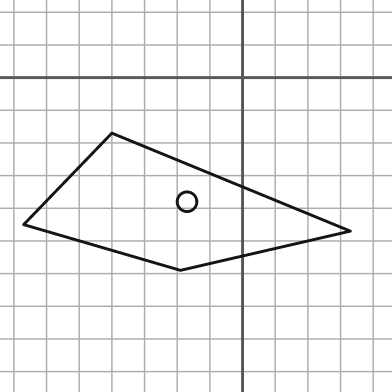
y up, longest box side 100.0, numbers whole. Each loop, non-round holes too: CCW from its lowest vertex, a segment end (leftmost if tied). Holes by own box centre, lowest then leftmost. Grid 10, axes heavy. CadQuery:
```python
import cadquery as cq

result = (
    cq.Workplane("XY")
    .moveTo(-19.0, -59.0)
    .lineTo(33.0, -47.0)
    .lineTo(-40.0, -17.0)
    .lineTo(-67.0, -45.0)
    .close()
    .moveTo(-17.0, -38.0)
    .circle(3.0)
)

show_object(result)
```